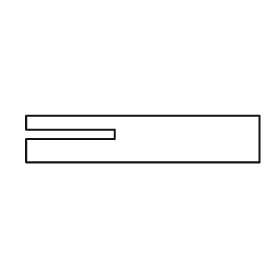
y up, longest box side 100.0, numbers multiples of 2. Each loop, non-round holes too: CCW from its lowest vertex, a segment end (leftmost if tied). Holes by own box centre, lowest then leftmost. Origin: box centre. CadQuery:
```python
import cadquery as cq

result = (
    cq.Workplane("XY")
    .moveTo(-50.0, -10.0)
    .lineTo(50.0, -10.0)
    .lineTo(50.0, 10.0)
    .lineTo(-50.0, 10.0)
    .lineTo(-50.0, 4.0)
    .lineTo(-12.0, 4.0)
    .lineTo(-12.0, 0.0)
    .lineTo(-50.0, 0.0)
    .close()
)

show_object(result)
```